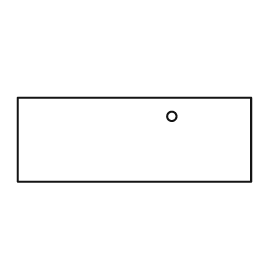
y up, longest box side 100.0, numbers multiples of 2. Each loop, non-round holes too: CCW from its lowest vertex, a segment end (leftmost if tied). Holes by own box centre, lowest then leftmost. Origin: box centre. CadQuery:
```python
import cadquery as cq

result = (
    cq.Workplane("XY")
    .moveTo(-50.0, -18.0)
    .lineTo(50.0, -18.0)
    .lineTo(50.0, 18.0)
    .lineTo(-50.0, 18.0)
    .close()
    .moveTo(16.0, 10.0)
    .circle(2.0)
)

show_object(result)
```